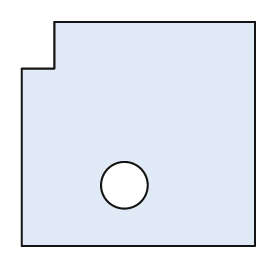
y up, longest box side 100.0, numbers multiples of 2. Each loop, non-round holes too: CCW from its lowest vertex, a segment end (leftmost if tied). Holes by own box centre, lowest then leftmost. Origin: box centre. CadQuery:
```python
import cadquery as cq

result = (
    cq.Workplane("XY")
    .moveTo(-50.0, -48.0)
    .lineTo(50.0, -48.0)
    .lineTo(50.0, 48.0)
    .lineTo(-36.0, 48.0)
    .lineTo(-36.0, 28.0)
    .lineTo(-50.0, 28.0)
    .close()
    .moveTo(-6.0, -22.0)
    .circle(10.0)
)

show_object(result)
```